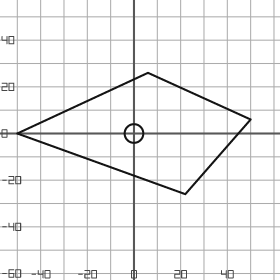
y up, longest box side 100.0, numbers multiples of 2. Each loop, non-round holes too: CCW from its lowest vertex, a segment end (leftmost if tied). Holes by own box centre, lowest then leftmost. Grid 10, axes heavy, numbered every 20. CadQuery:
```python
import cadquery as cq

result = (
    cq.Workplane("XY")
    .moveTo(22.0, -26.0)
    .lineTo(50.0, 6.0)
    .lineTo(6.0, 26.0)
    .lineTo(-50.0, 0.0)
    .close()
    .moveTo(0.0, 0.0)
    .circle(4.0)
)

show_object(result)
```